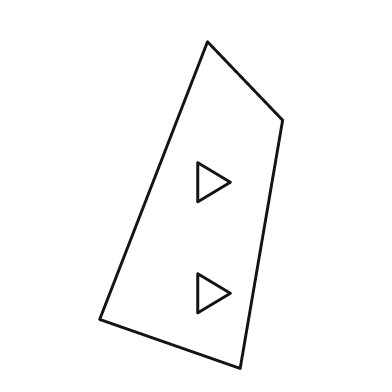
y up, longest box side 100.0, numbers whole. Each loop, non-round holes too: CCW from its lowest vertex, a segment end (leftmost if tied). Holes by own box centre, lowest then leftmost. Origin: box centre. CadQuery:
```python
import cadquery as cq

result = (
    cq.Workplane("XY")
    .moveTo(15.0, -50.0)
    .lineTo(28.0, 26.0)
    .lineTo(5.0, 50.0)
    .lineTo(-28.0, -35.0)
    .close()
    .moveTo(2.0, -33.0)
    .lineTo(12.0, -27.0)
    .lineTo(2.0, -21.0)
    .close()
    .moveTo(2.0, 1.0)
    .lineTo(12.0, 7.0)
    .lineTo(2.0, 13.0)
    .close()
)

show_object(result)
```